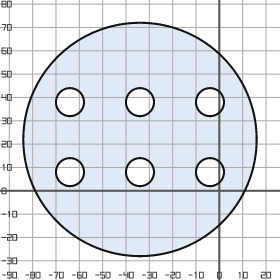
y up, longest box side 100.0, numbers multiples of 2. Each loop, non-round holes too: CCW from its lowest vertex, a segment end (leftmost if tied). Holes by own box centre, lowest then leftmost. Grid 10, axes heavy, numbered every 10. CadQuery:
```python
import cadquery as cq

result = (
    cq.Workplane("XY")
    .moveTo(-34.0, 22.0)
    .circle(50.0)
    .moveTo(-64.0, 8.0)
    .circle(6.0)
    .moveTo(-34.0, 8.0)
    .circle(6.0)
    .moveTo(-4.0, 8.0)
    .circle(6.0)
    .moveTo(-64.0, 38.0)
    .circle(6.0)
    .moveTo(-34.0, 38.0)
    .circle(6.0)
    .moveTo(-4.0, 38.0)
    .circle(6.0)
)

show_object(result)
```